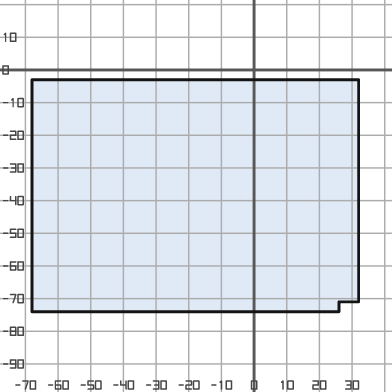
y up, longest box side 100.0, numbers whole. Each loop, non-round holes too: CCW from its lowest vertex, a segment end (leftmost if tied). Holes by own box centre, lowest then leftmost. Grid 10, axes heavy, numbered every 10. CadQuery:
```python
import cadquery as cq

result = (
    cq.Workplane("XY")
    .moveTo(-68.0, -74.0)
    .lineTo(26.0, -74.0)
    .lineTo(26.0, -71.0)
    .lineTo(32.0, -71.0)
    .lineTo(32.0, -3.0)
    .lineTo(-68.0, -3.0)
    .close()
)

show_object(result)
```